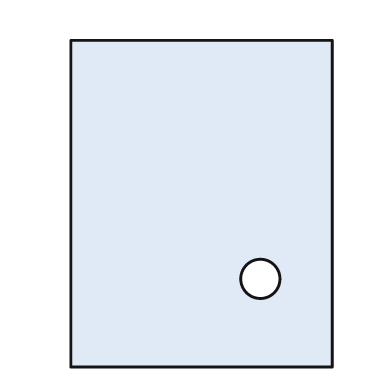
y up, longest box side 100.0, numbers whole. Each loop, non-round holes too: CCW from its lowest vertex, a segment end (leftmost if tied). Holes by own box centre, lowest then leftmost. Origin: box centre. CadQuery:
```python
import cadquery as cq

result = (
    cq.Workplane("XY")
    .moveTo(-40.0, -50.0)
    .lineTo(40.0, -50.0)
    .lineTo(40.0, 50.0)
    .lineTo(-40.0, 50.0)
    .close()
    .moveTo(18.0, -23.0)
    .circle(6.0)
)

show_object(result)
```